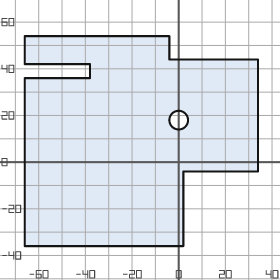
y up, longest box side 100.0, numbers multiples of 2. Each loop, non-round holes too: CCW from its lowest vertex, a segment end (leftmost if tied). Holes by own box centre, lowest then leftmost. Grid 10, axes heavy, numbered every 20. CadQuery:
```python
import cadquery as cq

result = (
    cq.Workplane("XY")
    .moveTo(-66.0, -36.0)
    .lineTo(2.0, -36.0)
    .lineTo(2.0, -4.0)
    .lineTo(34.0, -4.0)
    .lineTo(34.0, 44.0)
    .lineTo(-4.0, 44.0)
    .lineTo(-4.0, 54.0)
    .lineTo(-66.0, 54.0)
    .lineTo(-66.0, 42.0)
    .lineTo(-38.0, 42.0)
    .lineTo(-38.0, 36.0)
    .lineTo(-66.0, 36.0)
    .close()
    .moveTo(0.0, 18.0)
    .circle(4.0)
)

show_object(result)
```